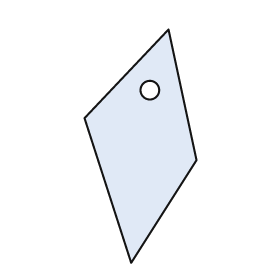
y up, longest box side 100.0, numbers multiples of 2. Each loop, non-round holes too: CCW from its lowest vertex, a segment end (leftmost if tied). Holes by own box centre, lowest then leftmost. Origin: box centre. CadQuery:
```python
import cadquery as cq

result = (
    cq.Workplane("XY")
    .moveTo(-4.0, -50.0)
    .lineTo(24.0, -6.0)
    .lineTo(12.0, 50.0)
    .lineTo(-24.0, 12.0)
    .close()
    .moveTo(4.0, 24.0)
    .circle(4.0)
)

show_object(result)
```